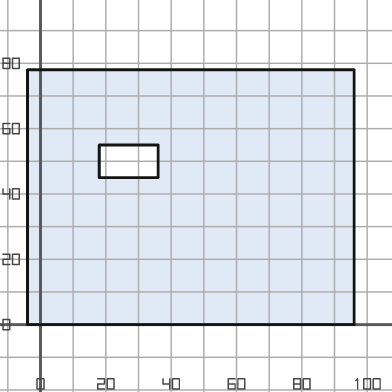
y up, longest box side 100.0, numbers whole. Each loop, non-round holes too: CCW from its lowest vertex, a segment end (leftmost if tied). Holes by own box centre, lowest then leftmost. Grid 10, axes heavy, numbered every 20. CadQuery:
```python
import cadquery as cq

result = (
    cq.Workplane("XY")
    .moveTo(-4.0, 0.0)
    .lineTo(96.0, 0.0)
    .lineTo(96.0, 78.0)
    .lineTo(-4.0, 78.0)
    .close()
    .moveTo(18.0, 45.0)
    .lineTo(36.0, 45.0)
    .lineTo(36.0, 55.0)
    .lineTo(18.0, 55.0)
    .close()
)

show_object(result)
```